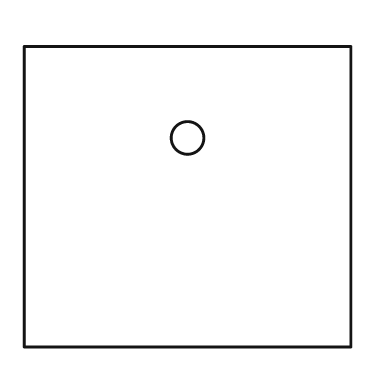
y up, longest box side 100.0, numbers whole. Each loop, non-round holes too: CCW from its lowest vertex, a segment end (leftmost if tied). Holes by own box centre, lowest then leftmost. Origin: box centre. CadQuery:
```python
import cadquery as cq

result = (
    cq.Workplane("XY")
    .moveTo(-50.0, -46.0)
    .lineTo(50.0, -46.0)
    .lineTo(50.0, 46.0)
    .lineTo(-50.0, 46.0)
    .close()
    .moveTo(0.0, 18.0)
    .circle(5.0)
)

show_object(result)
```